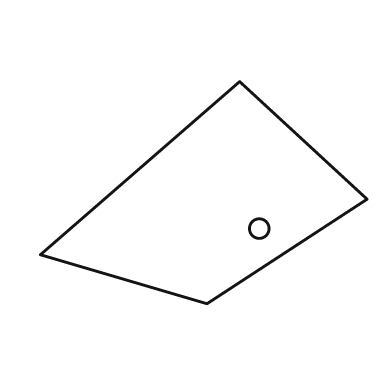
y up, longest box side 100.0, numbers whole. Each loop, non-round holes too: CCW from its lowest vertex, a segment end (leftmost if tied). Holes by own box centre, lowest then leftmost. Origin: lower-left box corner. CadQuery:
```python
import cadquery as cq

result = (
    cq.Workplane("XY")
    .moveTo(51.0, 0.0)
    .lineTo(100.0, 32.0)
    .lineTo(61.0, 68.0)
    .lineTo(0.0, 15.0)
    .close()
    .moveTo(67.0, 23.0)
    .circle(3.0)
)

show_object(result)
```